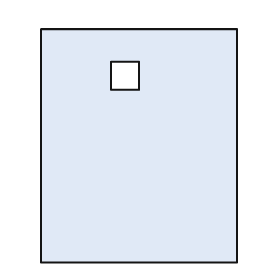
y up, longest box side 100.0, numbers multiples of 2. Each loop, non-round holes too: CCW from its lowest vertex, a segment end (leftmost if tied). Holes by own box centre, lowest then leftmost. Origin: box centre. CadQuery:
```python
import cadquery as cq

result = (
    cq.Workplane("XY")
    .moveTo(-42.0, -50.0)
    .lineTo(42.0, -50.0)
    .lineTo(42.0, 50.0)
    .lineTo(-42.0, 50.0)
    .close()
    .moveTo(-12.0, 24.0)
    .lineTo(0.0, 24.0)
    .lineTo(0.0, 36.0)
    .lineTo(-12.0, 36.0)
    .close()
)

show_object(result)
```